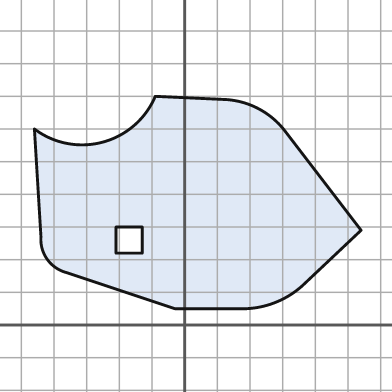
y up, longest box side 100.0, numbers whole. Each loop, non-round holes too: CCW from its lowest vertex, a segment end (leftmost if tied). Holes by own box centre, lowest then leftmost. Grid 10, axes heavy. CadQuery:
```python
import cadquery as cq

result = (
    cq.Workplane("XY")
    .moveTo(-3.0, 5.0)
    .lineTo(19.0, 5.0)
    .threePointArc((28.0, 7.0), (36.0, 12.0))
    .lineTo(54.0, 29.0)
    .lineTo(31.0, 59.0)
    .threePointArc((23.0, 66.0), (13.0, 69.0))
    .lineTo(-9.0, 70.0)
    .threePointArc((-25.0, 56.0), (-46.0, 60.0))
    .lineTo(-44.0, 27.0)
    .threePointArc((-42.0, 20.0), (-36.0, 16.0))
    .close()
    .moveTo(-21.0, 22.0)
    .lineTo(-13.0, 22.0)
    .lineTo(-13.0, 30.0)
    .lineTo(-21.0, 30.0)
    .close()
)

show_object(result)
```